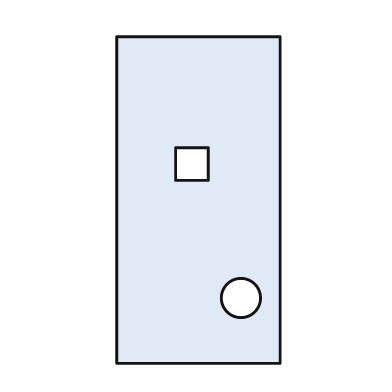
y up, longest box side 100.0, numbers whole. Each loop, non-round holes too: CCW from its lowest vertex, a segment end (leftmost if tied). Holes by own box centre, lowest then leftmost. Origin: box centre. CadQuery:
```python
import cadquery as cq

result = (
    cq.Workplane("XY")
    .moveTo(-25.0, -50.0)
    .lineTo(25.0, -50.0)
    .lineTo(25.0, 50.0)
    .lineTo(-25.0, 50.0)
    .close()
    .moveTo(13.0, -30.0)
    .circle(6.0)
    .moveTo(-7.0, 6.0)
    .lineTo(3.0, 6.0)
    .lineTo(3.0, 16.0)
    .lineTo(-7.0, 16.0)
    .close()
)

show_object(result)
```